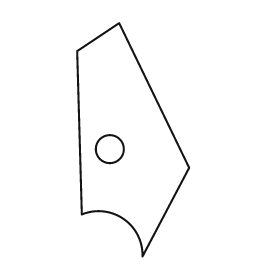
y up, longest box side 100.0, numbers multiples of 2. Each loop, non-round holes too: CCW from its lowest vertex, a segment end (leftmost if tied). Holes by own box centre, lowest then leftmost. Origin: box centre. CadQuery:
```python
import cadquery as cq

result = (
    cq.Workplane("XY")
    .moveTo(4.0, -50.0)
    .lineTo(24.0, -12.0)
    .lineTo(-6.0, 50.0)
    .lineTo(-24.0, 38.0)
    .lineTo(-22.0, -32.0)
    .threePointArc((-4.0, -34.0), (4.0, -50.0))
    .close()
    .moveTo(-10.0, -4.0)
    .circle(6.0)
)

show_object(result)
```